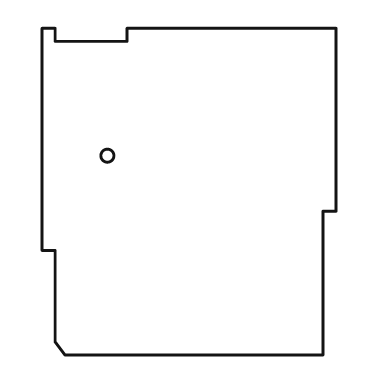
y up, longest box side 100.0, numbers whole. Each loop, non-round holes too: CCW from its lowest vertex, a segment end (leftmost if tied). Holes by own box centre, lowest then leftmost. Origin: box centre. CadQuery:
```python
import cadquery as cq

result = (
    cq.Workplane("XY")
    .moveTo(-38.0, -50.0)
    .lineTo(41.0, -50.0)
    .lineTo(41.0, -6.0)
    .lineTo(45.0, -6.0)
    .lineTo(45.0, 50.0)
    .lineTo(-19.0, 50.0)
    .lineTo(-19.0, 46.0)
    .lineTo(-41.0, 46.0)
    .lineTo(-41.0, 50.0)
    .lineTo(-45.0, 50.0)
    .lineTo(-45.0, -18.0)
    .lineTo(-41.0, -18.0)
    .lineTo(-41.0, -46.0)
    .close()
    .moveTo(-25.0, 11.0)
    .circle(2.0)
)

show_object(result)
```